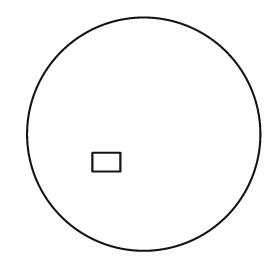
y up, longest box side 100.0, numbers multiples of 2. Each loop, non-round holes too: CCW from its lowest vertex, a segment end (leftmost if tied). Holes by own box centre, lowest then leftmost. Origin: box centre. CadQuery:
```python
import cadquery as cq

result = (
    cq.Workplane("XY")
    .moveTo(0.0, 0.0)
    .circle(50.0)
    .moveTo(-22.0, -16.0)
    .lineTo(-10.0, -16.0)
    .lineTo(-10.0, -8.0)
    .lineTo(-22.0, -8.0)
    .close()
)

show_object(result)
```